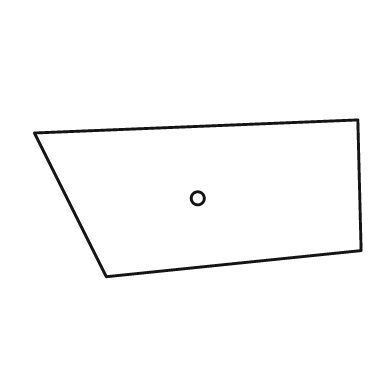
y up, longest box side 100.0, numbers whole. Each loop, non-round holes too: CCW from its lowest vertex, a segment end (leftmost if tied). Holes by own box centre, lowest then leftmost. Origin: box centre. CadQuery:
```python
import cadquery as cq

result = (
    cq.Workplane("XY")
    .moveTo(-28.0, -24.0)
    .lineTo(50.0, -16.0)
    .lineTo(49.0, 24.0)
    .lineTo(-50.0, 20.0)
    .close()
    .moveTo(0.0, 0.0)
    .circle(2.0)
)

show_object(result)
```